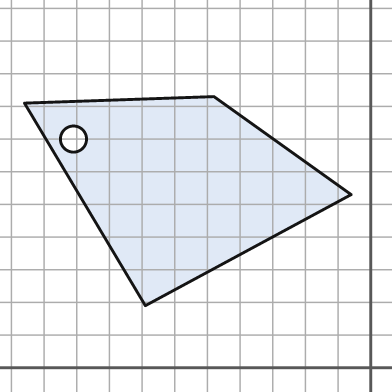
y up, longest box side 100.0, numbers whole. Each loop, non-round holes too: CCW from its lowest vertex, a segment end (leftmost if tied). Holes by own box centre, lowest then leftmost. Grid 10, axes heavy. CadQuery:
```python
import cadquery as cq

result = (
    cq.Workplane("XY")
    .moveTo(-69.0, 19.0)
    .lineTo(-6.0, 53.0)
    .lineTo(-48.0, 83.0)
    .lineTo(-106.0, 81.0)
    .close()
    .moveTo(-91.0, 70.0)
    .circle(4.0)
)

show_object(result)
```